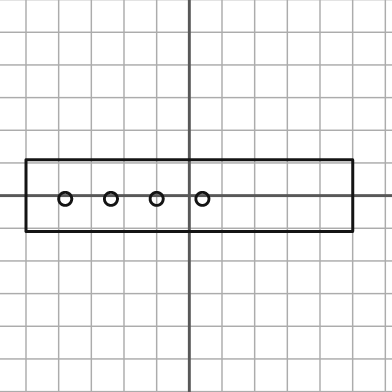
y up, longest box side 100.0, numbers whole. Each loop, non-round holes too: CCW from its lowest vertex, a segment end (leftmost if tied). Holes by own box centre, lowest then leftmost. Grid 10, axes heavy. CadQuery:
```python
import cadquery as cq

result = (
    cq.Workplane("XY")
    .moveTo(-50.0, -11.0)
    .lineTo(50.0, -11.0)
    .lineTo(50.0, 11.0)
    .lineTo(-50.0, 11.0)
    .close()
    .moveTo(-38.0, -1.0)
    .circle(2.0)
    .moveTo(-24.0, -1.0)
    .circle(2.0)
    .moveTo(-10.0, -1.0)
    .circle(2.0)
    .moveTo(4.0, -1.0)
    .circle(2.0)
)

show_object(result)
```